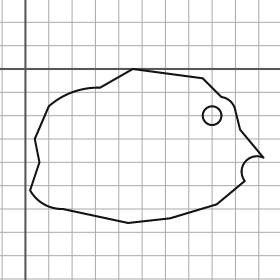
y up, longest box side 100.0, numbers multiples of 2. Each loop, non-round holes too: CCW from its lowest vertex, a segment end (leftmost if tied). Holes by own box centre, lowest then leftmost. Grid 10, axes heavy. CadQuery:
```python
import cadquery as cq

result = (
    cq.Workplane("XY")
    .moveTo(44.0, -66.0)
    .lineTo(62.0, -64.0)
    .lineTo(82.0, -58.0)
    .lineTo(94.0, -48.0)
    .threePointArc((94.0, -40.0), (102.0, -38.0))
    .lineTo(92.0, -26.0)
    .lineTo(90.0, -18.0)
    .threePointArc((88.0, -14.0), (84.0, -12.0))
    .lineTo(76.0, -4.0)
    .lineTo(46.0, 0.0)
    .lineTo(32.0, -8.0)
    .threePointArc((20.0, -10.0), (10.0, -16.0))
    .lineTo(4.0, -30.0)
    .lineTo(6.0, -40.0)
    .lineTo(2.0, -52.0)
    .threePointArc((8.0, -58.0), (16.0, -60.0))
    .close()
    .moveTo(80.0, -20.0)
    .circle(4.0)
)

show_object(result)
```